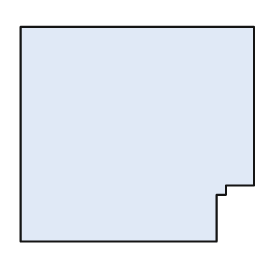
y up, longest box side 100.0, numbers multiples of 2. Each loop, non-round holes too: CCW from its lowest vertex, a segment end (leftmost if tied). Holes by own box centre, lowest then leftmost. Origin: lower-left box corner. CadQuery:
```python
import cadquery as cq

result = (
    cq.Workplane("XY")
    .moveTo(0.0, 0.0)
    .lineTo(84.0, 0.0)
    .lineTo(84.0, 20.0)
    .lineTo(88.0, 20.0)
    .lineTo(88.0, 24.0)
    .lineTo(100.0, 24.0)
    .lineTo(100.0, 92.0)
    .lineTo(0.0, 92.0)
    .close()
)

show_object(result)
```